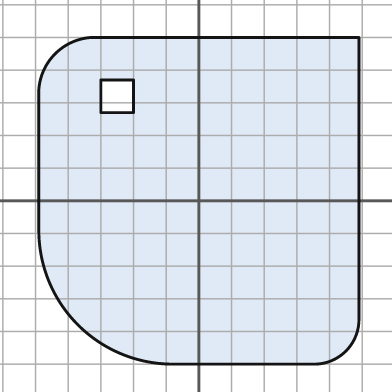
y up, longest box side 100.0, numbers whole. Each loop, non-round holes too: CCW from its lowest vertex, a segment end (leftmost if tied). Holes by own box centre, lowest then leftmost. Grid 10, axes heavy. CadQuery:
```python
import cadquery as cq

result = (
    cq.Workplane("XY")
    .moveTo(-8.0, -50.0)
    .lineTo(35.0, -50.0)
    .threePointArc((45.0, -46.0), (49.0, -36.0))
    .lineTo(49.0, 50.0)
    .lineTo(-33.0, 50.0)
    .threePointArc((-44.0, 45.0), (-49.0, 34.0))
    .lineTo(-49.0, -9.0)
    .threePointArc((-37.0, -38.0), (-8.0, -50.0))
    .close()
    .moveTo(-30.0, 27.0)
    .lineTo(-20.0, 27.0)
    .lineTo(-20.0, 37.0)
    .lineTo(-30.0, 37.0)
    .close()
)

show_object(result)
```